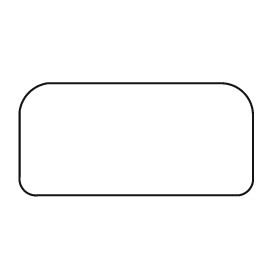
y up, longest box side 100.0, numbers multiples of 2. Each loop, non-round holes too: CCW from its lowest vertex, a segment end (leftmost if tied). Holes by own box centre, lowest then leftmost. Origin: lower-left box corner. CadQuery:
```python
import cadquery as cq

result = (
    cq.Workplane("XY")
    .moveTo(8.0, 0.0)
    .lineTo(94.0, 0.0)
    .threePointArc((98.0, 2.0), (100.0, 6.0))
    .lineTo(100.0, 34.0)
    .threePointArc((96.0, 44.0), (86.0, 48.0))
    .lineTo(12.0, 48.0)
    .threePointArc((4.0, 44.0), (0.0, 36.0))
    .lineTo(0.0, 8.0)
    .threePointArc((2.0, 2.0), (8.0, 0.0))
    .close()
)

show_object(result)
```